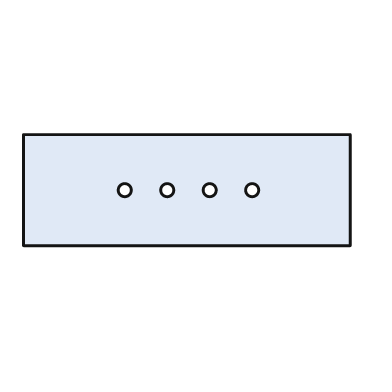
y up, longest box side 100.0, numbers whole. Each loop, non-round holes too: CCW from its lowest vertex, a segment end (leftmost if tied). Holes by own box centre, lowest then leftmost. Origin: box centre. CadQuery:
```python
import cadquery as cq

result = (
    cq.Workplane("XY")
    .moveTo(-50.0, -17.0)
    .lineTo(50.0, -17.0)
    .lineTo(50.0, 17.0)
    .lineTo(-50.0, 17.0)
    .close()
    .moveTo(-19.0, 0.0)
    .circle(2.0)
    .moveTo(-6.0, 0.0)
    .circle(2.0)
    .moveTo(7.0, 0.0)
    .circle(2.0)
    .moveTo(20.0, 0.0)
    .circle(2.0)
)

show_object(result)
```